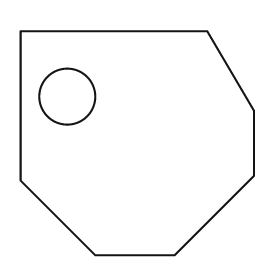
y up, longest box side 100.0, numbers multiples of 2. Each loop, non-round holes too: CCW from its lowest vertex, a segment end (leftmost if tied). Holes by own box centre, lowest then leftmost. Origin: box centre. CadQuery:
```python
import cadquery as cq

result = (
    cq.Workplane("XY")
    .moveTo(-18.0, -48.0)
    .lineTo(16.0, -48.0)
    .lineTo(50.0, -14.0)
    .lineTo(50.0, 14.0)
    .lineTo(30.0, 48.0)
    .lineTo(-50.0, 48.0)
    .lineTo(-50.0, -16.0)
    .close()
    .moveTo(-30.0, 20.0)
    .circle(12.0)
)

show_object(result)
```